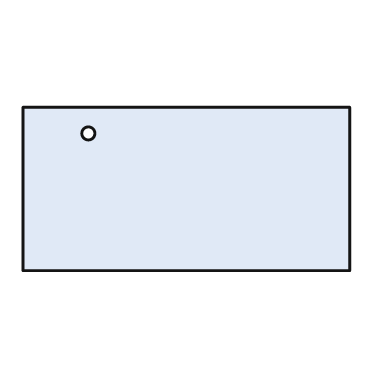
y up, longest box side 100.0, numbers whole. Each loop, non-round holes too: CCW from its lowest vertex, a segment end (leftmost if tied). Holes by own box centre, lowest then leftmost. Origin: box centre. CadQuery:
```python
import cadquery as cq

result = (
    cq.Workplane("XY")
    .moveTo(-50.0, -25.0)
    .lineTo(50.0, -25.0)
    .lineTo(50.0, 25.0)
    .lineTo(-50.0, 25.0)
    .close()
    .moveTo(-30.0, 17.0)
    .circle(2.0)
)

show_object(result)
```